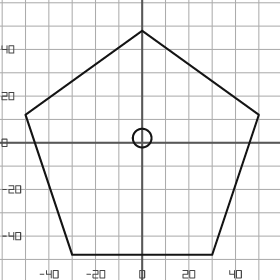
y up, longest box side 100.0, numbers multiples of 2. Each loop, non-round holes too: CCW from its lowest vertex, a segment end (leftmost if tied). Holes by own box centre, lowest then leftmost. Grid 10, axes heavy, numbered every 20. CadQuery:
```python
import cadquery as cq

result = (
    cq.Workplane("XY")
    .moveTo(-30.0, -48.0)
    .lineTo(30.0, -48.0)
    .lineTo(50.0, 12.0)
    .lineTo(0.0, 48.0)
    .lineTo(-50.0, 12.0)
    .close()
    .moveTo(0.0, 2.0)
    .circle(4.0)
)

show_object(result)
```